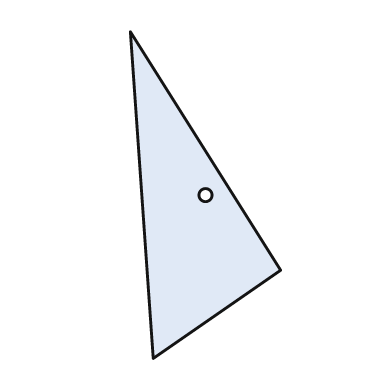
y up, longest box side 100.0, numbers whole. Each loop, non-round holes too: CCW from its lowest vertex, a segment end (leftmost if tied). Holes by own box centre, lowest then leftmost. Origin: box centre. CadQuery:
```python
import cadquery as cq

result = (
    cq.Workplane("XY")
    .moveTo(-16.0, -50.0)
    .lineTo(23.0, -23.0)
    .lineTo(-23.0, 50.0)
    .close()
    .moveTo(0.0, 0.0)
    .circle(2.0)
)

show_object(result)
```